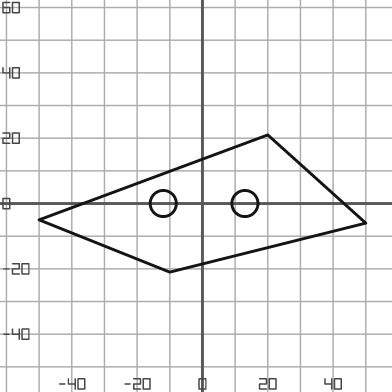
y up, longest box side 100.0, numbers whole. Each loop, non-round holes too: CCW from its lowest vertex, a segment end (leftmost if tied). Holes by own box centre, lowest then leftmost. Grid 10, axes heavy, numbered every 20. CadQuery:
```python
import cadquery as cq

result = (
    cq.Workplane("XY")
    .moveTo(-10.0, -21.0)
    .lineTo(50.0, -6.0)
    .lineTo(20.0, 21.0)
    .lineTo(-50.0, -5.0)
    .close()
    .moveTo(-12.0, 0.0)
    .circle(4.0)
    .moveTo(13.0, 0.0)
    .circle(4.0)
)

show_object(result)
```